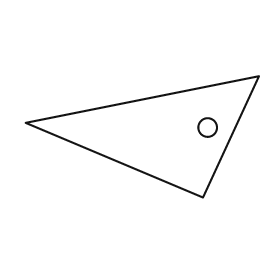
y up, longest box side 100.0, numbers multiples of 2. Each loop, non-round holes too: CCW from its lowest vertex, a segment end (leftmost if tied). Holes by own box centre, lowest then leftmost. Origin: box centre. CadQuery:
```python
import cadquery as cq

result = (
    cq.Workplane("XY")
    .moveTo(26.0, -26.0)
    .lineTo(50.0, 26.0)
    .lineTo(-50.0, 6.0)
    .close()
    .moveTo(28.0, 4.0)
    .circle(4.0)
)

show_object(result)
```